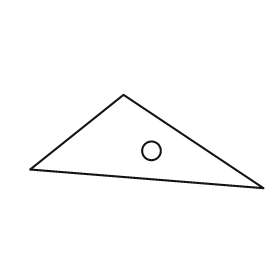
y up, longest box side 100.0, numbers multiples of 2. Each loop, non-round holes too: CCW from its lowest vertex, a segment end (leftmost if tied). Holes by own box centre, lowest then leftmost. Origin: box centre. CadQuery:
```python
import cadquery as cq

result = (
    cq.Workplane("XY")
    .moveTo(50.0, -20.0)
    .lineTo(-10.0, 20.0)
    .lineTo(-50.0, -12.0)
    .close()
    .moveTo(2.0, -4.0)
    .circle(4.0)
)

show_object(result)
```